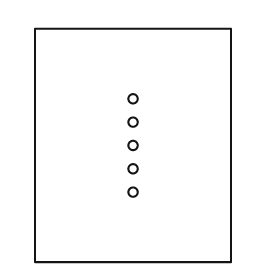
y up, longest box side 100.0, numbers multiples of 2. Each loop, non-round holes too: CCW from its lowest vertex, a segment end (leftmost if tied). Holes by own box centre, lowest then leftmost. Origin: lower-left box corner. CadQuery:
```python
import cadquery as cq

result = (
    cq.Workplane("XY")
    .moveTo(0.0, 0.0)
    .lineTo(84.0, 0.0)
    .lineTo(84.0, 100.0)
    .lineTo(0.0, 100.0)
    .close()
    .moveTo(42.0, 30.0)
    .circle(2.0)
    .moveTo(42.0, 40.0)
    .circle(2.0)
    .moveTo(42.0, 50.0)
    .circle(2.0)
    .moveTo(42.0, 60.0)
    .circle(2.0)
    .moveTo(42.0, 70.0)
    .circle(2.0)
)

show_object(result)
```